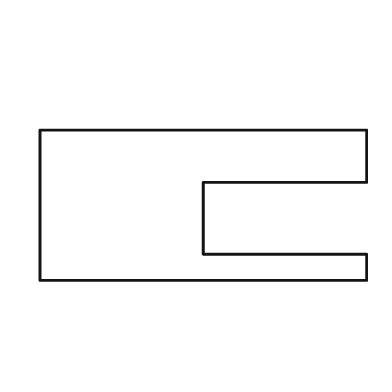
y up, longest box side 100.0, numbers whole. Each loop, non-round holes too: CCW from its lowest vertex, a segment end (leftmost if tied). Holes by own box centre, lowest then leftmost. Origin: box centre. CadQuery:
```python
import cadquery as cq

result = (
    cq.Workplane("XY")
    .moveTo(-50.0, -23.0)
    .lineTo(50.0, -23.0)
    .lineTo(50.0, -15.0)
    .lineTo(0.0, -15.0)
    .lineTo(0.0, 7.0)
    .lineTo(50.0, 7.0)
    .lineTo(50.0, 23.0)
    .lineTo(-50.0, 23.0)
    .close()
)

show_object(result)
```